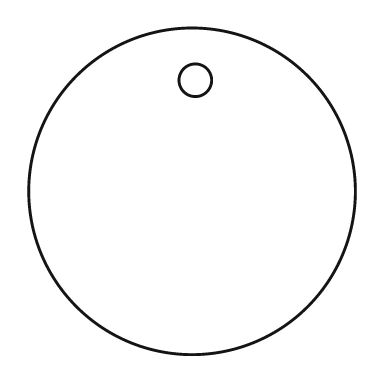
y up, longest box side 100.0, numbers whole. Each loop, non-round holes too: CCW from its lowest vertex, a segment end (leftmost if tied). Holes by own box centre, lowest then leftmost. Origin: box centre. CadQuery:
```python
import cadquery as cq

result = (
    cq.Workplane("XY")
    .moveTo(0.0, 0.0)
    .circle(50.0)
    .moveTo(1.0, 34.0)
    .circle(5.0)
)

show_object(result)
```